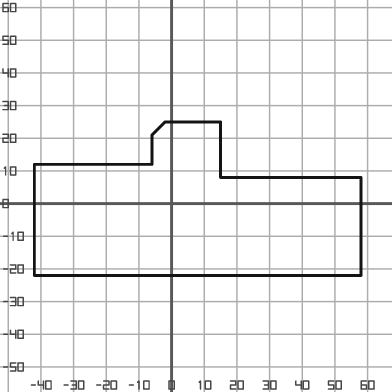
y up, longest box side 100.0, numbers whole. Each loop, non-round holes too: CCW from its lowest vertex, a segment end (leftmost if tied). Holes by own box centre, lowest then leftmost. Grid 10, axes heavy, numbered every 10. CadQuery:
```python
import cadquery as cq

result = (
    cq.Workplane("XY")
    .moveTo(-42.0, -22.0)
    .lineTo(58.0, -22.0)
    .lineTo(58.0, 8.0)
    .lineTo(15.0, 8.0)
    .lineTo(15.0, 25.0)
    .lineTo(-2.0, 25.0)
    .lineTo(-6.0, 21.0)
    .lineTo(-6.0, 12.0)
    .lineTo(-42.0, 12.0)
    .close()
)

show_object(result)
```